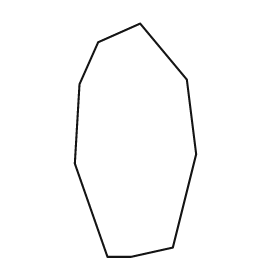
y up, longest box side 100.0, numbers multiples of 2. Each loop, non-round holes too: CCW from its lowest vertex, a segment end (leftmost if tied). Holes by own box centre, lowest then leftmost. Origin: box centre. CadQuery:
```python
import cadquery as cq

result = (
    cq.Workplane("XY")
    .moveTo(-12.0, -50.0)
    .lineTo(-2.0, -50.0)
    .lineTo(16.0, -46.0)
    .lineTo(26.0, -6.0)
    .lineTo(22.0, 26.0)
    .lineTo(2.0, 50.0)
    .lineTo(-16.0, 42.0)
    .lineTo(-24.0, 24.0)
    .lineTo(-26.0, -10.0)
    .close()
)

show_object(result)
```